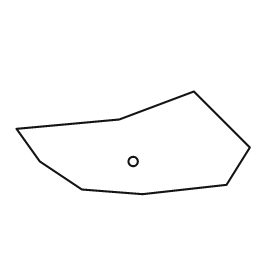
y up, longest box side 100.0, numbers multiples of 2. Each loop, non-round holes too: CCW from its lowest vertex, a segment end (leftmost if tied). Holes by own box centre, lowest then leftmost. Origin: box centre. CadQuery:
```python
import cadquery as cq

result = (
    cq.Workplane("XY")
    .moveTo(4.0, -22.0)
    .lineTo(40.0, -18.0)
    .lineTo(50.0, -2.0)
    .lineTo(26.0, 22.0)
    .lineTo(-6.0, 10.0)
    .lineTo(-50.0, 6.0)
    .lineTo(-40.0, -8.0)
    .lineTo(-22.0, -20.0)
    .close()
    .moveTo(0.0, -8.0)
    .circle(2.0)
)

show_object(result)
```